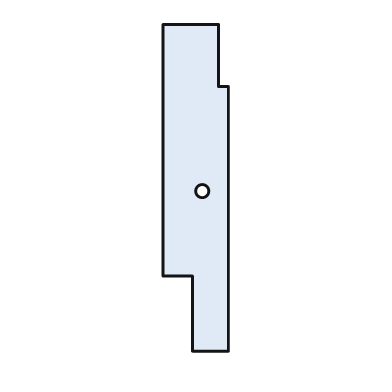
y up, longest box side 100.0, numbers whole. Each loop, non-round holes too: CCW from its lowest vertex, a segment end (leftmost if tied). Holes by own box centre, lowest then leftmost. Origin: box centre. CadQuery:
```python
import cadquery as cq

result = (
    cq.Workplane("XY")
    .moveTo(-1.0, -50.0)
    .lineTo(10.0, -50.0)
    .lineTo(10.0, 31.0)
    .lineTo(7.0, 31.0)
    .lineTo(7.0, 50.0)
    .lineTo(-10.0, 50.0)
    .lineTo(-10.0, -27.0)
    .lineTo(-1.0, -27.0)
    .close()
    .moveTo(2.0, -1.0)
    .circle(2.0)
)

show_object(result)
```